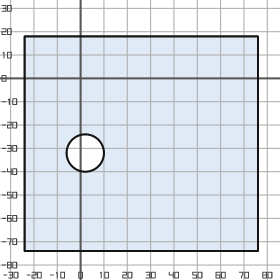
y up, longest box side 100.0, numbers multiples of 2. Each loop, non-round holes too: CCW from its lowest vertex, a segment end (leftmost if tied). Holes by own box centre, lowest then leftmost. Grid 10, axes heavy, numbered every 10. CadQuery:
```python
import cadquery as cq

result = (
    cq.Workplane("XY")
    .moveTo(-24.0, -74.0)
    .lineTo(76.0, -74.0)
    .lineTo(76.0, 18.0)
    .lineTo(-24.0, 18.0)
    .close()
    .moveTo(2.0, -32.0)
    .circle(8.0)
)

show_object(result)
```